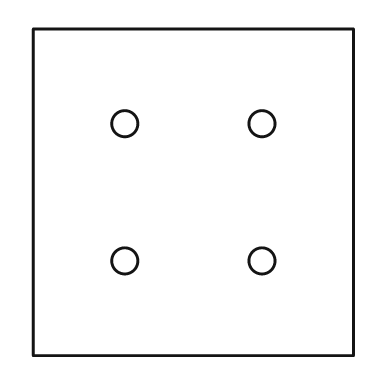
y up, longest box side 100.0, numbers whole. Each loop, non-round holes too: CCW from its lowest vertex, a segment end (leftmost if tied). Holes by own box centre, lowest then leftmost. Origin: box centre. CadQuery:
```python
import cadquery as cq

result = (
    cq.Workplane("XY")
    .moveTo(-49.0, -50.0)
    .lineTo(49.0, -50.0)
    .lineTo(49.0, 50.0)
    .lineTo(-49.0, 50.0)
    .close()
    .moveTo(-21.0, -21.0)
    .circle(4.0)
    .moveTo(21.0, -21.0)
    .circle(4.0)
    .moveTo(-21.0, 21.0)
    .circle(4.0)
    .moveTo(21.0, 21.0)
    .circle(4.0)
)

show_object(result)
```